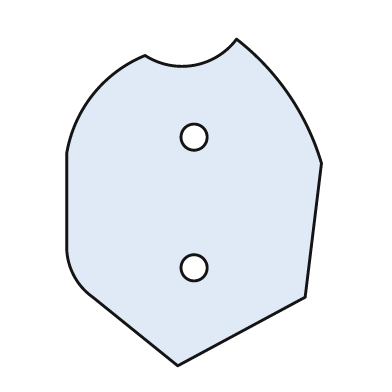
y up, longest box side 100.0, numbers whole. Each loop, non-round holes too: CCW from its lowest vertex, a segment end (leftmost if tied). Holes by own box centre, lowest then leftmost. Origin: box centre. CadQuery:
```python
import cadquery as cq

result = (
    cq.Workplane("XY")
    .moveTo(-5.0, -50.0)
    .lineTo(34.0, -29.0)
    .lineTo(39.0, 12.0)
    .threePointArc((29.0, 33.0), (13.0, 50.0))
    .threePointArc((0.0, 42.0), (-15.0, 45.0))
    .threePointArc((-31.0, 33.0), (-39.0, 15.0))
    .lineTo(-39.0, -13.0)
    .threePointArc((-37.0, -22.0), (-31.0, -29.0))
    .close()
    .moveTo(0.0, -20.0)
    .circle(4.0)
    .moveTo(0.0, 20.0)
    .circle(4.0)
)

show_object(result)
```